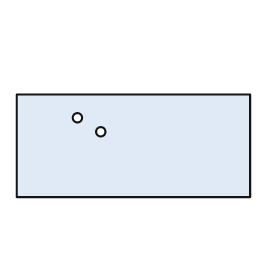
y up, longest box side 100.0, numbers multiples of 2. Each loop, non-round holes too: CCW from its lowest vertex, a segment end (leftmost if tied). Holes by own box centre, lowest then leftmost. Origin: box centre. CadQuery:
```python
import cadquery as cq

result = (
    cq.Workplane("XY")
    .moveTo(-50.0, -22.0)
    .lineTo(50.0, -22.0)
    .lineTo(50.0, 22.0)
    .lineTo(-50.0, 22.0)
    .close()
    .moveTo(-14.0, 6.0)
    .circle(2.0)
    .moveTo(-24.0, 12.0)
    .circle(2.0)
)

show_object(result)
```